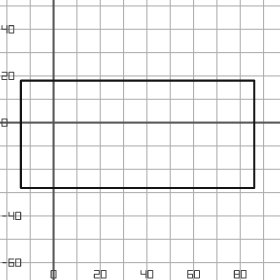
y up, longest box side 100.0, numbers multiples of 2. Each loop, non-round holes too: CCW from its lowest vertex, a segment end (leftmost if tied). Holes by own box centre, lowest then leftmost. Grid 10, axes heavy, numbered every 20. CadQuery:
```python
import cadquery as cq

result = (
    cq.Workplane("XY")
    .moveTo(-14.0, -28.0)
    .lineTo(86.0, -28.0)
    .lineTo(86.0, 18.0)
    .lineTo(-14.0, 18.0)
    .close()
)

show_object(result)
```